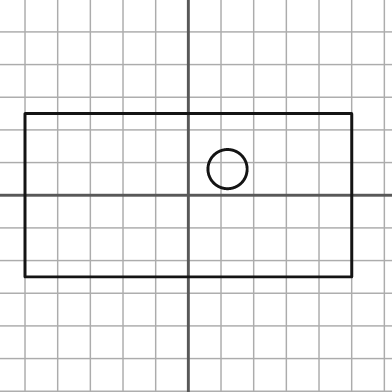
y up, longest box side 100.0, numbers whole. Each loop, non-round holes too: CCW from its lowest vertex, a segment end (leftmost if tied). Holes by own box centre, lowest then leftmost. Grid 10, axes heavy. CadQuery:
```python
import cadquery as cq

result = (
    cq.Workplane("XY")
    .moveTo(-50.0, -25.0)
    .lineTo(50.0, -25.0)
    .lineTo(50.0, 25.0)
    .lineTo(-50.0, 25.0)
    .close()
    .moveTo(12.0, 8.0)
    .circle(6.0)
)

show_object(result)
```